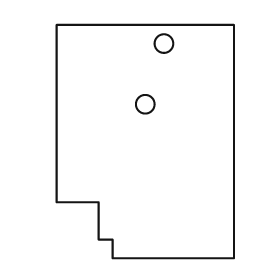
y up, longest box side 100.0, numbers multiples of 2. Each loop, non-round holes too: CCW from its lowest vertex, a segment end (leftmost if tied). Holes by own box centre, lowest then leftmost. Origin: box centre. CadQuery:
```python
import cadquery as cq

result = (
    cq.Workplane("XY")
    .moveTo(-14.0, -50.0)
    .lineTo(38.0, -50.0)
    .lineTo(38.0, 50.0)
    .lineTo(-38.0, 50.0)
    .lineTo(-38.0, -26.0)
    .lineTo(-20.0, -26.0)
    .lineTo(-20.0, -42.0)
    .lineTo(-14.0, -42.0)
    .close()
    .moveTo(0.0, 16.0)
    .circle(4.0)
    .moveTo(8.0, 42.0)
    .circle(4.0)
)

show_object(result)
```